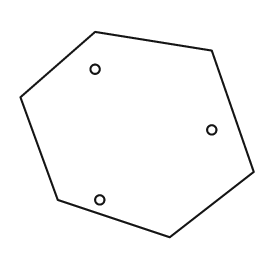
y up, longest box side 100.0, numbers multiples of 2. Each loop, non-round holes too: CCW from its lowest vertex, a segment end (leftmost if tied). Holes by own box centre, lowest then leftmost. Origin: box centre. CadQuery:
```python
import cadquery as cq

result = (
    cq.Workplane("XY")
    .moveTo(14.0, -44.0)
    .lineTo(50.0, -16.0)
    .lineTo(32.0, 36.0)
    .lineTo(-18.0, 44.0)
    .lineTo(-50.0, 16.0)
    .lineTo(-34.0, -28.0)
    .close()
    .moveTo(-16.0, -28.0)
    .circle(2.0)
    .moveTo(32.0, 2.0)
    .circle(2.0)
    .moveTo(-18.0, 28.0)
    .circle(2.0)
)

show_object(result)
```